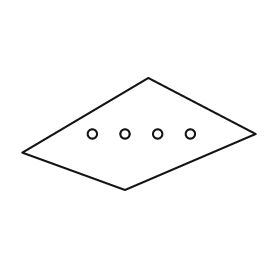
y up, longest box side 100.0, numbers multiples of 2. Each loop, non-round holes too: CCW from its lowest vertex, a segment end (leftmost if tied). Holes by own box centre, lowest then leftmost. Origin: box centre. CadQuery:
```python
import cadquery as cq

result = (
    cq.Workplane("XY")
    .moveTo(-6.0, -24.0)
    .lineTo(50.0, 0.0)
    .lineTo(4.0, 24.0)
    .lineTo(-50.0, -8.0)
    .close()
    .moveTo(-20.0, 0.0)
    .circle(2.0)
    .moveTo(-6.0, 0.0)
    .circle(2.0)
    .moveTo(8.0, 0.0)
    .circle(2.0)
    .moveTo(22.0, 0.0)
    .circle(2.0)
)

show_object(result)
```